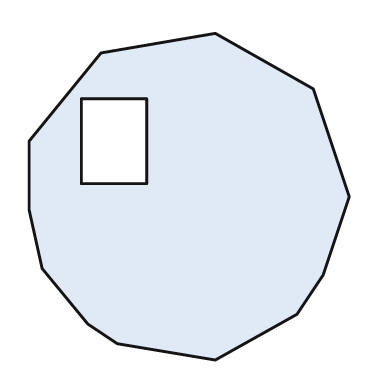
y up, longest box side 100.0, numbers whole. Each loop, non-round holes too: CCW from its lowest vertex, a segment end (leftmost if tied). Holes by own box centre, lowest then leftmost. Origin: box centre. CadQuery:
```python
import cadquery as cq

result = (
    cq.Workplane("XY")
    .moveTo(8.0, -50.0)
    .lineTo(33.0, -36.0)
    .lineTo(41.0, -24.0)
    .lineTo(49.0, 0.0)
    .lineTo(38.0, 33.0)
    .lineTo(8.0, 50.0)
    .lineTo(-27.0, 44.0)
    .lineTo(-49.0, 17.0)
    .lineTo(-49.0, -4.0)
    .lineTo(-45.0, -22.0)
    .lineTo(-31.0, -39.0)
    .lineTo(-22.0, -45.0)
    .close()
    .moveTo(-33.0, 4.0)
    .lineTo(-13.0, 4.0)
    .lineTo(-13.0, 30.0)
    .lineTo(-33.0, 30.0)
    .close()
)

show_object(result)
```